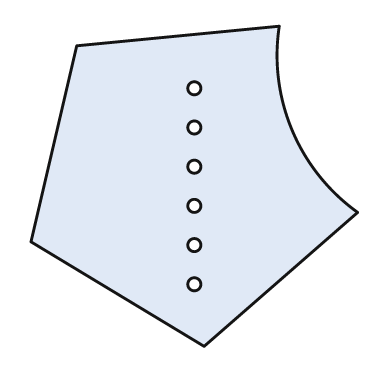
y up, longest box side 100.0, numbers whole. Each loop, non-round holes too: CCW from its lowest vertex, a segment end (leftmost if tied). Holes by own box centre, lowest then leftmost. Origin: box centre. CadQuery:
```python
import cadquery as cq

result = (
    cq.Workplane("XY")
    .moveTo(3.0, -49.0)
    .lineTo(50.0, -8.0)
    .threePointArc((30.0, 17.0), (26.0, 49.0))
    .lineTo(-36.0, 43.0)
    .lineTo(-50.0, -17.0)
    .close()
    .moveTo(0.0, -30.0)
    .circle(2.0)
    .moveTo(0.0, -18.0)
    .circle(2.0)
    .moveTo(0.0, -6.0)
    .circle(2.0)
    .moveTo(0.0, 6.0)
    .circle(2.0)
    .moveTo(0.0, 18.0)
    .circle(2.0)
    .moveTo(0.0, 30.0)
    .circle(2.0)
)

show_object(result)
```